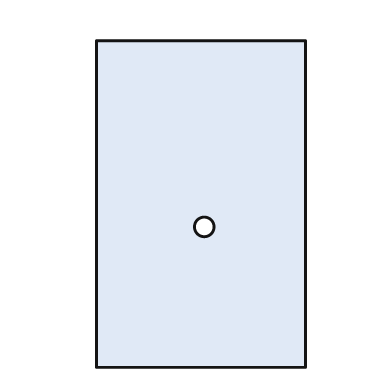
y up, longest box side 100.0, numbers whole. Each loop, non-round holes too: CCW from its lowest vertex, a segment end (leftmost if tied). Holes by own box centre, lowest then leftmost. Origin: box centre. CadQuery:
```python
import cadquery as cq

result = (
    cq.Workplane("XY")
    .moveTo(-32.0, -50.0)
    .lineTo(32.0, -50.0)
    .lineTo(32.0, 50.0)
    .lineTo(-32.0, 50.0)
    .close()
    .moveTo(1.0, -7.0)
    .circle(3.0)
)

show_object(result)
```